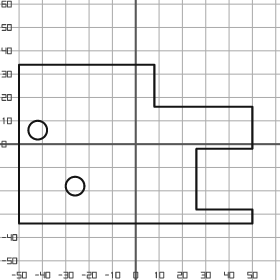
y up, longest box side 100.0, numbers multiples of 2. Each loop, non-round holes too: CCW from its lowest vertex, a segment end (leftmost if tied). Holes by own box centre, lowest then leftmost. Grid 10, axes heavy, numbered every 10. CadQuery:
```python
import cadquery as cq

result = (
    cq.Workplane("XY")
    .moveTo(-50.0, -34.0)
    .lineTo(50.0, -34.0)
    .lineTo(50.0, -28.0)
    .lineTo(26.0, -28.0)
    .lineTo(26.0, -2.0)
    .lineTo(50.0, -2.0)
    .lineTo(50.0, 16.0)
    .lineTo(8.0, 16.0)
    .lineTo(8.0, 34.0)
    .lineTo(-50.0, 34.0)
    .close()
    .moveTo(-26.0, -18.0)
    .circle(4.0)
    .moveTo(-42.0, 6.0)
    .circle(4.0)
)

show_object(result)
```